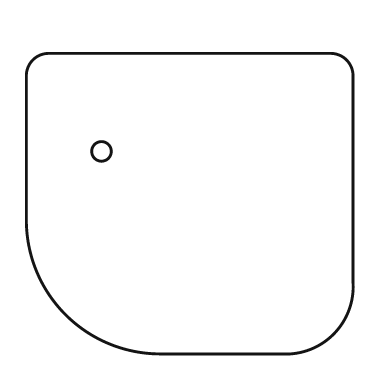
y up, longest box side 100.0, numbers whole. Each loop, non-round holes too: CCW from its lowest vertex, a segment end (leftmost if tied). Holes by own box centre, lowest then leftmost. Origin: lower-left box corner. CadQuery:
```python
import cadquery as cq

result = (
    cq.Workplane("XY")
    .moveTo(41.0, 0.0)
    .lineTo(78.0, 0.0)
    .threePointArc((94.0, 6.0), (100.0, 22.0))
    .lineTo(100.0, 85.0)
    .threePointArc((98.0, 90.0), (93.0, 92.0))
    .lineTo(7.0, 92.0)
    .threePointArc((2.0, 90.0), (0.0, 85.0))
    .lineTo(0.0, 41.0)
    .threePointArc((12.0, 12.0), (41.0, 0.0))
    .close()
    .moveTo(23.0, 62.0)
    .circle(3.0)
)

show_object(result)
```